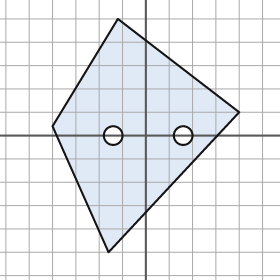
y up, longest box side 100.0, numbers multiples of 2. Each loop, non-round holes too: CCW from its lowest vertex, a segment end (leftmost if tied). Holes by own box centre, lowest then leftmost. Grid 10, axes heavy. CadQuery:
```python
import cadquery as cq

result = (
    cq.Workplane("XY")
    .moveTo(-16.0, -50.0)
    .lineTo(40.0, 10.0)
    .lineTo(-12.0, 50.0)
    .lineTo(-40.0, 4.0)
    .close()
    .moveTo(-14.0, 0.0)
    .circle(4.0)
    .moveTo(16.0, 0.0)
    .circle(4.0)
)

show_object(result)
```